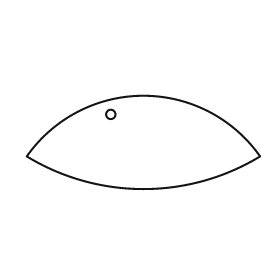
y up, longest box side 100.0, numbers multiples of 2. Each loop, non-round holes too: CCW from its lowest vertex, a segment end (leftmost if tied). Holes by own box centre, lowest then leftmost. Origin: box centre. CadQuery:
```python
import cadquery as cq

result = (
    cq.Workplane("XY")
    .moveTo(-50.0, -6.0)
    .threePointArc((0.0, -20.0), (50.0, -6.0))
    .threePointArc((0.0, 20.0), (-50.0, -6.0))
    .close()
    .moveTo(-14.0, 12.0)
    .circle(2.0)
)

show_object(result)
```